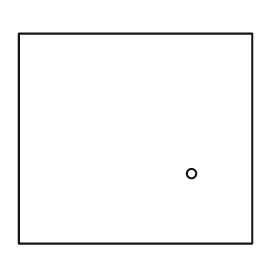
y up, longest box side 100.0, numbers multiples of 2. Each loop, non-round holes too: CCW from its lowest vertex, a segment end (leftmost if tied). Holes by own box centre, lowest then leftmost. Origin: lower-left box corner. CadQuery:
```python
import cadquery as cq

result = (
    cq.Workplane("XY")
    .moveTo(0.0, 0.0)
    .lineTo(100.0, 0.0)
    .lineTo(100.0, 90.0)
    .lineTo(0.0, 90.0)
    .close()
    .moveTo(74.0, 30.0)
    .circle(2.0)
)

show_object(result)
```